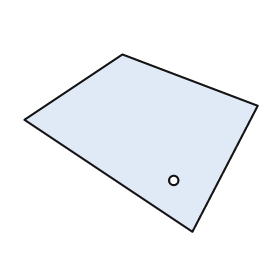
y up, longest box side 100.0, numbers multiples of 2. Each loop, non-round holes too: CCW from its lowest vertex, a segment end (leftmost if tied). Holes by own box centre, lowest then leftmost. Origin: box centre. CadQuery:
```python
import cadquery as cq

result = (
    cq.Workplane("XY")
    .moveTo(22.0, -38.0)
    .lineTo(50.0, 16.0)
    .lineTo(-8.0, 38.0)
    .lineTo(-50.0, 10.0)
    .close()
    .moveTo(14.0, -16.0)
    .circle(2.0)
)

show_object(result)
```